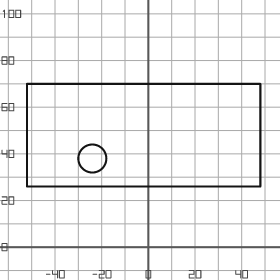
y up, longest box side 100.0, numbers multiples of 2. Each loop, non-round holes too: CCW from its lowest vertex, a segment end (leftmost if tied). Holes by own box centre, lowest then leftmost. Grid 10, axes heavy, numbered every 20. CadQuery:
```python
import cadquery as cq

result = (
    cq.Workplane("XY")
    .moveTo(-52.0, 26.0)
    .lineTo(48.0, 26.0)
    .lineTo(48.0, 70.0)
    .lineTo(-52.0, 70.0)
    .close()
    .moveTo(-24.0, 38.0)
    .circle(6.0)
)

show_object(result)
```